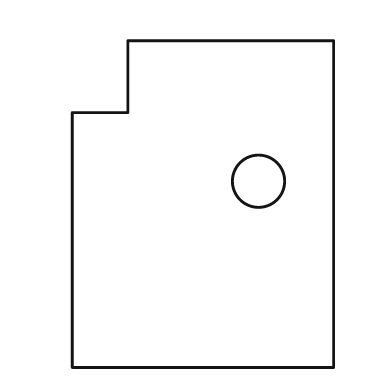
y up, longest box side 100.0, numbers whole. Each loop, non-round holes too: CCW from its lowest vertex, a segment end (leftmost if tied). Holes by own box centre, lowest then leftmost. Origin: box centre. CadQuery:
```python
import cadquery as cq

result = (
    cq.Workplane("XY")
    .moveTo(-40.0, -50.0)
    .lineTo(40.0, -50.0)
    .lineTo(40.0, 50.0)
    .lineTo(-23.0, 50.0)
    .lineTo(-23.0, 28.0)
    .lineTo(-40.0, 28.0)
    .close()
    .moveTo(17.0, 7.0)
    .circle(8.0)
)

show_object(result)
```